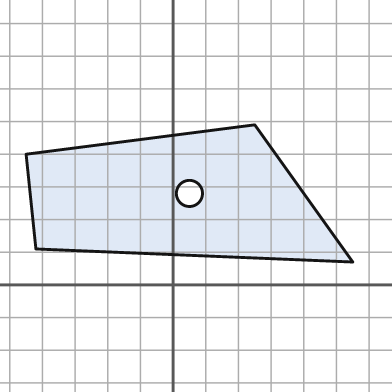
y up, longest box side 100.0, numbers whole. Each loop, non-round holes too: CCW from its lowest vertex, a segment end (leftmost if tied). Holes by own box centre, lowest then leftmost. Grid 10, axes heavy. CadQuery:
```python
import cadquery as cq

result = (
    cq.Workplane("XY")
    .moveTo(55.0, 7.0)
    .lineTo(25.0, 49.0)
    .lineTo(-45.0, 40.0)
    .lineTo(-42.0, 11.0)
    .close()
    .moveTo(5.0, 28.0)
    .circle(4.0)
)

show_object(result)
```